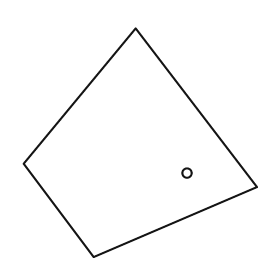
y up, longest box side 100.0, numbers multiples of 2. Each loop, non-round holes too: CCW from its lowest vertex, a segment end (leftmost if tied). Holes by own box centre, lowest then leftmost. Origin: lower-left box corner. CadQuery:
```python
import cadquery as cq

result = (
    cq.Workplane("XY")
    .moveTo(30.0, 0.0)
    .lineTo(100.0, 30.0)
    .lineTo(48.0, 98.0)
    .lineTo(0.0, 40.0)
    .close()
    .moveTo(70.0, 36.0)
    .circle(2.0)
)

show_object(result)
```